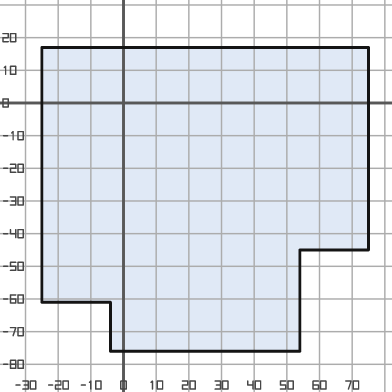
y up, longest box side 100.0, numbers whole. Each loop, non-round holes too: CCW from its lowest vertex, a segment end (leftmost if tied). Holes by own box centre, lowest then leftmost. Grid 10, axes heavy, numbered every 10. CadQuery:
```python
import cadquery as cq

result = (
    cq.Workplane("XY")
    .moveTo(-4.0, -76.0)
    .lineTo(54.0, -76.0)
    .lineTo(54.0, -45.0)
    .lineTo(75.0, -45.0)
    .lineTo(75.0, 17.0)
    .lineTo(-25.0, 17.0)
    .lineTo(-25.0, -61.0)
    .lineTo(-4.0, -61.0)
    .close()
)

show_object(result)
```